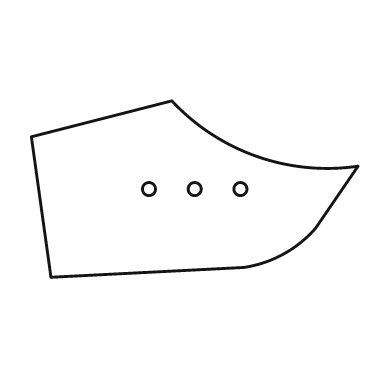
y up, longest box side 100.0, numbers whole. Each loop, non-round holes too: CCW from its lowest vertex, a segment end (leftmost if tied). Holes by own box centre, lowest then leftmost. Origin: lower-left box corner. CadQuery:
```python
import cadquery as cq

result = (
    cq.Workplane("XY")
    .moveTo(6.0, 0.0)
    .lineTo(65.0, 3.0)
    .threePointArc((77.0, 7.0), (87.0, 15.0))
    .lineTo(100.0, 34.0)
    .threePointArc((69.0, 37.0), (43.0, 54.0))
    .lineTo(0.0, 43.0)
    .close()
    .moveTo(36.0, 27.0)
    .circle(2.0)
    .moveTo(50.0, 27.0)
    .circle(2.0)
    .moveTo(64.0, 27.0)
    .circle(2.0)
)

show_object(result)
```